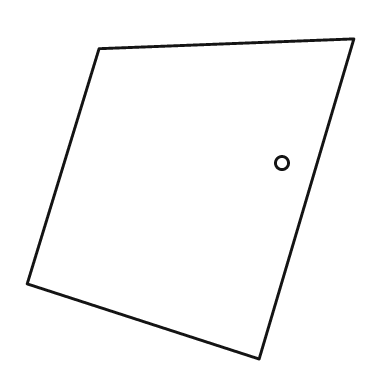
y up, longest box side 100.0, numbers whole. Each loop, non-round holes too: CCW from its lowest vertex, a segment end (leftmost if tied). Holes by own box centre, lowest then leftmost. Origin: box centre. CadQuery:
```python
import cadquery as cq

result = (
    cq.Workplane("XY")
    .moveTo(21.0, -49.0)
    .lineTo(50.0, 49.0)
    .lineTo(-28.0, 46.0)
    .lineTo(-50.0, -26.0)
    .close()
    .moveTo(28.0, 11.0)
    .circle(2.0)
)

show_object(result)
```